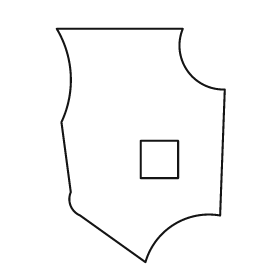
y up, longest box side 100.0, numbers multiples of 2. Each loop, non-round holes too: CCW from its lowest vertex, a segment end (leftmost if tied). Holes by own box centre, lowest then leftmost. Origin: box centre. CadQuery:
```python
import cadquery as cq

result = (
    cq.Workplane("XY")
    .moveTo(2.0, -50.0)
    .threePointArc((14.0, -34.0), (34.0, -30.0))
    .lineTo(36.0, 24.0)
    .threePointArc((20.0, 32.0), (18.0, 50.0))
    .lineTo(-36.0, 50.0)
    .threePointArc((-30.0, 30.0), (-34.0, 10.0))
    .lineTo(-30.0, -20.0)
    .threePointArc((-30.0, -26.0), (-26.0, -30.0))
    .close()
    .moveTo(0.0, -14.0)
    .lineTo(16.0, -14.0)
    .lineTo(16.0, 2.0)
    .lineTo(0.0, 2.0)
    .close()
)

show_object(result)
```